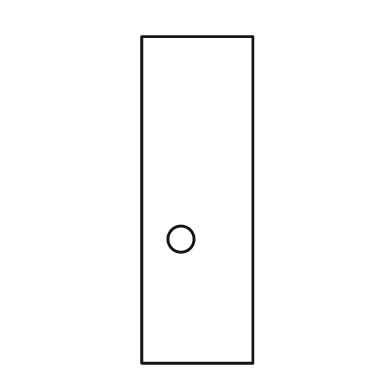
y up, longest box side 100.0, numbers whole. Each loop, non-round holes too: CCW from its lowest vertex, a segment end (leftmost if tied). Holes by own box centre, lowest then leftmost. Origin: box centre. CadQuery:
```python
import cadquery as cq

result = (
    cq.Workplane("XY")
    .moveTo(-17.0, -50.0)
    .lineTo(17.0, -50.0)
    .lineTo(17.0, 50.0)
    .lineTo(-17.0, 50.0)
    .close()
    .moveTo(-5.0, -12.0)
    .circle(4.0)
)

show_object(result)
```